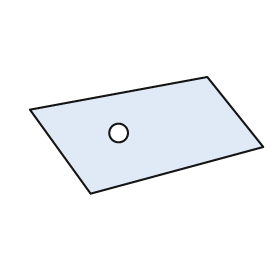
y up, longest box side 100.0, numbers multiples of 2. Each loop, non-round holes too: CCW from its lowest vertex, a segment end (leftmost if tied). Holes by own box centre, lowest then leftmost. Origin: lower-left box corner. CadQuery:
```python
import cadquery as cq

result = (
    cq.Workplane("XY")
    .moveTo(26.0, 0.0)
    .lineTo(100.0, 20.0)
    .lineTo(76.0, 50.0)
    .lineTo(0.0, 36.0)
    .close()
    .moveTo(38.0, 26.0)
    .circle(4.0)
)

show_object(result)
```